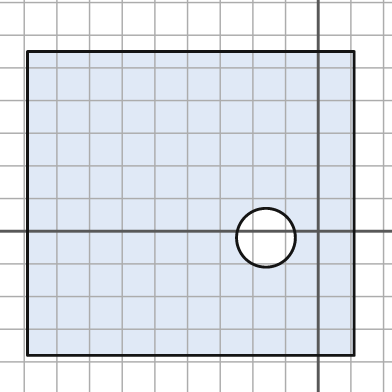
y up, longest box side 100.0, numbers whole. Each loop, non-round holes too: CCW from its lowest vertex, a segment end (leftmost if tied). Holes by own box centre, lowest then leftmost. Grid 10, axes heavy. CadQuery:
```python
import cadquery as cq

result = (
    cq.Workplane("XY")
    .moveTo(-89.0, -38.0)
    .lineTo(11.0, -38.0)
    .lineTo(11.0, 55.0)
    .lineTo(-89.0, 55.0)
    .close()
    .moveTo(-16.0, -2.0)
    .circle(9.0)
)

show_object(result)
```